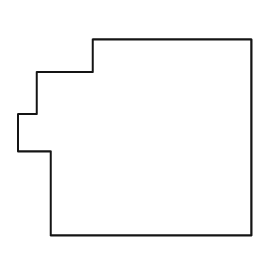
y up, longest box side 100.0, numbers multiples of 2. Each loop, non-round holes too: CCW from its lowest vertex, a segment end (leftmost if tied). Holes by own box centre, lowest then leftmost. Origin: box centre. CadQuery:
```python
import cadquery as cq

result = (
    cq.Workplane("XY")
    .moveTo(-36.0, -42.0)
    .lineTo(50.0, -42.0)
    .lineTo(50.0, 42.0)
    .lineTo(-18.0, 42.0)
    .lineTo(-18.0, 28.0)
    .lineTo(-42.0, 28.0)
    .lineTo(-42.0, 10.0)
    .lineTo(-50.0, 10.0)
    .lineTo(-50.0, -6.0)
    .lineTo(-36.0, -6.0)
    .close()
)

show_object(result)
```